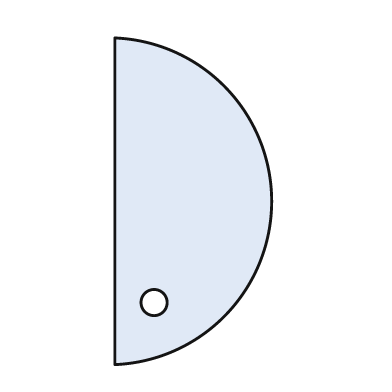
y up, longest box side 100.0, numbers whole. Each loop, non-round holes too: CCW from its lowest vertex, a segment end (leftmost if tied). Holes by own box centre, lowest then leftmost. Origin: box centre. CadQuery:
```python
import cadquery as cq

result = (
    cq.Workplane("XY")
    .moveTo(-24.0, -50.0)
    .threePointArc((24.0, 0.0), (-24.0, 50.0))
    .close()
    .moveTo(-12.0, -31.0)
    .circle(4.0)
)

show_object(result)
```